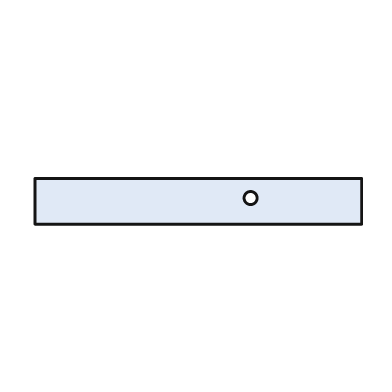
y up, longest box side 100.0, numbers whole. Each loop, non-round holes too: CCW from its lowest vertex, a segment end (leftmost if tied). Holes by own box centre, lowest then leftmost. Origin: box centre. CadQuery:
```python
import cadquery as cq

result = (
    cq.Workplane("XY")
    .moveTo(-50.0, -7.0)
    .lineTo(50.0, -7.0)
    .lineTo(50.0, 7.0)
    .lineTo(-50.0, 7.0)
    .close()
    .moveTo(16.0, 1.0)
    .circle(2.0)
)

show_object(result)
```